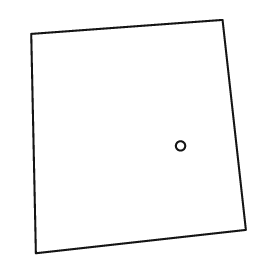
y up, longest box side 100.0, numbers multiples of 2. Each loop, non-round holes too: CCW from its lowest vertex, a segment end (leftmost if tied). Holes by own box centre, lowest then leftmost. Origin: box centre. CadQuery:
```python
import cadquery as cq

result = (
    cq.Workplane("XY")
    .moveTo(-44.0, -50.0)
    .lineTo(46.0, -40.0)
    .lineTo(36.0, 50.0)
    .lineTo(-46.0, 44.0)
    .close()
    .moveTo(18.0, -4.0)
    .circle(2.0)
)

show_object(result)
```